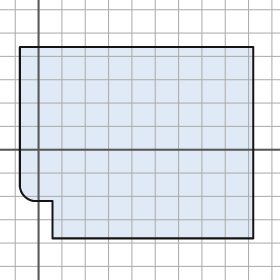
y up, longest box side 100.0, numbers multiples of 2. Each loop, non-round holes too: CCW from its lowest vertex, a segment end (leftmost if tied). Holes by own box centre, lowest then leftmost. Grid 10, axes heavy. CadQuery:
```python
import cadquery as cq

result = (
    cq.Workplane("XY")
    .moveTo(6.0, -38.0)
    .lineTo(92.0, -38.0)
    .lineTo(92.0, 44.0)
    .lineTo(-8.0, 44.0)
    .lineTo(-8.0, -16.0)
    .threePointArc((-6.0, -20.0), (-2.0, -22.0))
    .lineTo(6.0, -22.0)
    .close()
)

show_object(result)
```